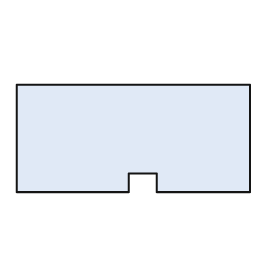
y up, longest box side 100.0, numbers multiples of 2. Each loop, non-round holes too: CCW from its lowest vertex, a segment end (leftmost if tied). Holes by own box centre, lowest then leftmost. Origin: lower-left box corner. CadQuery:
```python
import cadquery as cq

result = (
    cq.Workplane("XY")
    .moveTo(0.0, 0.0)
    .lineTo(48.0, 0.0)
    .lineTo(48.0, 8.0)
    .lineTo(60.0, 8.0)
    .lineTo(60.0, 0.0)
    .lineTo(100.0, 0.0)
    .lineTo(100.0, 46.0)
    .lineTo(0.0, 46.0)
    .close()
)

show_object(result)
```